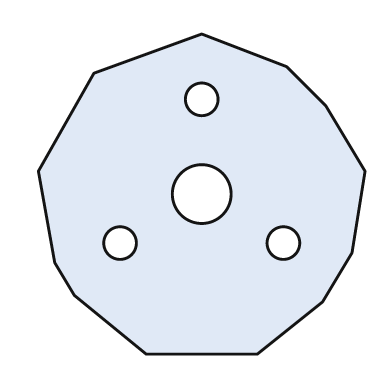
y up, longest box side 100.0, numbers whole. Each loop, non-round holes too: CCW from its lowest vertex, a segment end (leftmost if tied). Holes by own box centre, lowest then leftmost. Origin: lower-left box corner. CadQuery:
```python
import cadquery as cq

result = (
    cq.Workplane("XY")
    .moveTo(33.0, 0.0)
    .lineTo(67.0, 0.0)
    .lineTo(87.0, 16.0)
    .lineTo(96.0, 31.0)
    .lineTo(100.0, 56.0)
    .lineTo(88.0, 76.0)
    .lineTo(76.0, 88.0)
    .lineTo(50.0, 98.0)
    .lineTo(17.0, 86.0)
    .lineTo(0.0, 56.0)
    .lineTo(5.0, 28.0)
    .lineTo(11.0, 18.0)
    .close()
    .moveTo(25.0, 34.0)
    .circle(5.0)
    .moveTo(75.0, 34.0)
    .circle(5.0)
    .moveTo(50.0, 49.0)
    .circle(9.0)
    .moveTo(50.0, 78.0)
    .circle(5.0)
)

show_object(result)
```